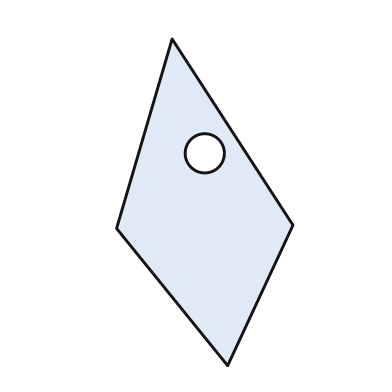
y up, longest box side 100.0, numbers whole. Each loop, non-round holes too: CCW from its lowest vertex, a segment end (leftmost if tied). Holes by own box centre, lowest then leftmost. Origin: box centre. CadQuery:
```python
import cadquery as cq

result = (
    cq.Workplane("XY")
    .moveTo(7.0, -50.0)
    .lineTo(27.0, -7.0)
    .lineTo(-10.0, 50.0)
    .lineTo(-27.0, -8.0)
    .close()
    .moveTo(0.0, 15.0)
    .circle(6.0)
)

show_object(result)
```